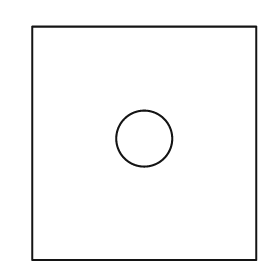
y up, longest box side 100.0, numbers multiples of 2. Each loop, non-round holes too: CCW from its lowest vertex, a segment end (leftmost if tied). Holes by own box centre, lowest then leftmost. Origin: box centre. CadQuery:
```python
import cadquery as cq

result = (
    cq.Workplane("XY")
    .moveTo(-48.0, -50.0)
    .lineTo(48.0, -50.0)
    .lineTo(48.0, 50.0)
    .lineTo(-48.0, 50.0)
    .close()
    .moveTo(0.0, 2.0)
    .circle(12.0)
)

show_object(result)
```